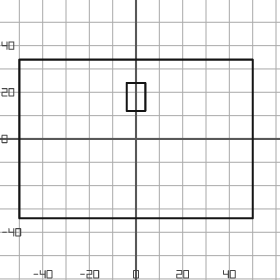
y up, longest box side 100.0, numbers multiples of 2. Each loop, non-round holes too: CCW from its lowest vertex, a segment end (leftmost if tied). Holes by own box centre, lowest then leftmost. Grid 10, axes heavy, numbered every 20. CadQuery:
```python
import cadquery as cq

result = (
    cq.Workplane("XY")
    .moveTo(-50.0, -34.0)
    .lineTo(50.0, -34.0)
    .lineTo(50.0, 34.0)
    .lineTo(-50.0, 34.0)
    .close()
    .moveTo(-4.0, 12.0)
    .lineTo(4.0, 12.0)
    .lineTo(4.0, 24.0)
    .lineTo(-4.0, 24.0)
    .close()
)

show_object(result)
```